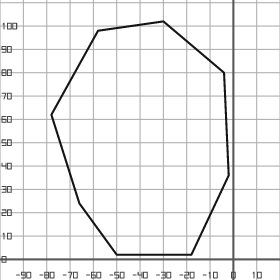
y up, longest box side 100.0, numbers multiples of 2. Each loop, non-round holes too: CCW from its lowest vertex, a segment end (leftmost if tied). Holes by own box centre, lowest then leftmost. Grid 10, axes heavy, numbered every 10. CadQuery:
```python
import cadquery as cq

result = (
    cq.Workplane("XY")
    .moveTo(-50.0, 2.0)
    .lineTo(-18.0, 2.0)
    .lineTo(-2.0, 36.0)
    .lineTo(-4.0, 80.0)
    .lineTo(-30.0, 102.0)
    .lineTo(-58.0, 98.0)
    .lineTo(-78.0, 62.0)
    .lineTo(-66.0, 24.0)
    .close()
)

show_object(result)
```